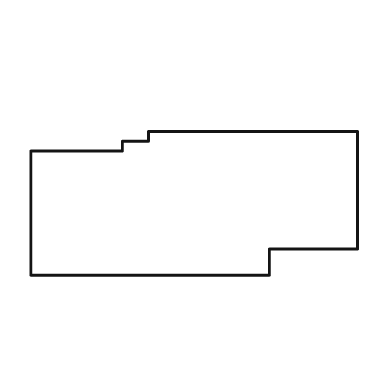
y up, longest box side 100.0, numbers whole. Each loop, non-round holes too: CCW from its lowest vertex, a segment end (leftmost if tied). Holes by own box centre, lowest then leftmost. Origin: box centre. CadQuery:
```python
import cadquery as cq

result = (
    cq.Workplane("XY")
    .moveTo(-50.0, -22.0)
    .lineTo(23.0, -22.0)
    .lineTo(23.0, -14.0)
    .lineTo(50.0, -14.0)
    .lineTo(50.0, 22.0)
    .lineTo(-14.0, 22.0)
    .lineTo(-14.0, 19.0)
    .lineTo(-22.0, 19.0)
    .lineTo(-22.0, 16.0)
    .lineTo(-50.0, 16.0)
    .close()
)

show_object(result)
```